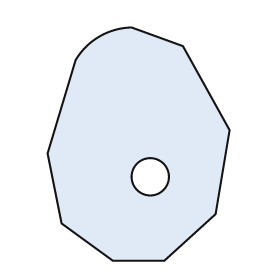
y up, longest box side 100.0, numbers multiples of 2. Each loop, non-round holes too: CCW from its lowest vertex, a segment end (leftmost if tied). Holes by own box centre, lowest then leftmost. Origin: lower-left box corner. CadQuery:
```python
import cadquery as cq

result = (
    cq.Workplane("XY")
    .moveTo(28.0, 0.0)
    .lineTo(50.0, 0.0)
    .lineTo(72.0, 20.0)
    .lineTo(78.0, 56.0)
    .lineTo(58.0, 92.0)
    .lineTo(36.0, 100.0)
    .threePointArc((22.0, 96.0), (12.0, 86.0))
    .lineTo(0.0, 46.0)
    .lineTo(6.0, 16.0)
    .close()
    .moveTo(44.0, 36.0)
    .circle(8.0)
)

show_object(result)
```